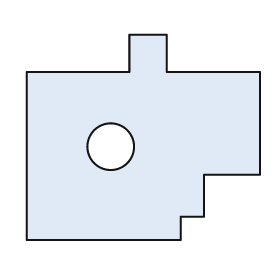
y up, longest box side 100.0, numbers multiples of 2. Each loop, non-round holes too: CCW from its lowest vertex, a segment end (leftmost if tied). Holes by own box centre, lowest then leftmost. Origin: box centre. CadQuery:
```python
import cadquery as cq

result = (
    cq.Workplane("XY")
    .moveTo(-50.0, -44.0)
    .lineTo(16.0, -44.0)
    .lineTo(16.0, -34.0)
    .lineTo(26.0, -34.0)
    .lineTo(26.0, -16.0)
    .lineTo(50.0, -16.0)
    .lineTo(50.0, 28.0)
    .lineTo(10.0, 28.0)
    .lineTo(10.0, 44.0)
    .lineTo(-6.0, 44.0)
    .lineTo(-6.0, 28.0)
    .lineTo(-50.0, 28.0)
    .close()
    .moveTo(-14.0, -4.0)
    .circle(10.0)
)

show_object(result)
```